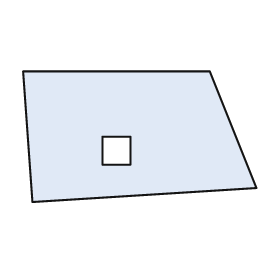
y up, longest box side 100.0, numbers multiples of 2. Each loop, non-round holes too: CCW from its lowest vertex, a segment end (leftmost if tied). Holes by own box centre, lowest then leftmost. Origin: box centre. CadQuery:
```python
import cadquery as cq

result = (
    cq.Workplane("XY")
    .moveTo(-46.0, -28.0)
    .lineTo(50.0, -22.0)
    .lineTo(30.0, 28.0)
    .lineTo(-50.0, 28.0)
    .close()
    .moveTo(-16.0, -12.0)
    .lineTo(-4.0, -12.0)
    .lineTo(-4.0, 0.0)
    .lineTo(-16.0, 0.0)
    .close()
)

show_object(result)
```